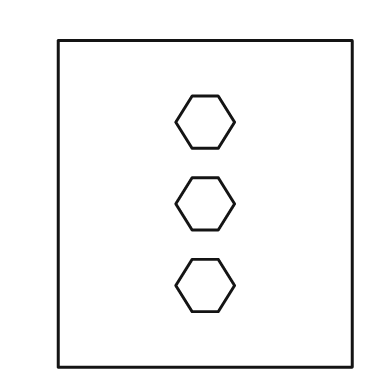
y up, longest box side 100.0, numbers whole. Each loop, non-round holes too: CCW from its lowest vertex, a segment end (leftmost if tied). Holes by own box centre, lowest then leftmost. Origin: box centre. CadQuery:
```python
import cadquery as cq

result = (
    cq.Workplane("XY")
    .moveTo(-45.0, -50.0)
    .lineTo(45.0, -50.0)
    .lineTo(45.0, 50.0)
    .lineTo(-45.0, 50.0)
    .close()
    .moveTo(-4.0, -33.0)
    .lineTo(4.0, -33.0)
    .lineTo(9.0, -25.0)
    .lineTo(4.0, -17.0)
    .lineTo(-4.0, -17.0)
    .lineTo(-9.0, -25.0)
    .close()
    .moveTo(-4.0, -8.0)
    .lineTo(4.0, -8.0)
    .lineTo(9.0, 0.0)
    .lineTo(4.0, 8.0)
    .lineTo(-4.0, 8.0)
    .lineTo(-9.0, 0.0)
    .close()
    .moveTo(-4.0, 17.0)
    .lineTo(4.0, 17.0)
    .lineTo(9.0, 25.0)
    .lineTo(4.0, 33.0)
    .lineTo(-4.0, 33.0)
    .lineTo(-9.0, 25.0)
    .close()
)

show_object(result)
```